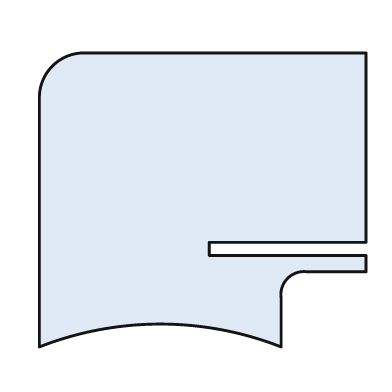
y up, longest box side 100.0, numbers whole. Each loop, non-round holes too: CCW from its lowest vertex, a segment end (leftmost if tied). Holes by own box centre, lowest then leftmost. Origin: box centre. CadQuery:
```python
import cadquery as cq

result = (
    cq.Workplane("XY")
    .moveTo(-50.0, -45.0)
    .threePointArc((-13.0, -38.0), (24.0, -45.0))
    .lineTo(24.0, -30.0)
    .threePointArc((26.0, -24.0), (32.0, -22.0))
    .lineTo(50.0, -22.0)
    .lineTo(50.0, -17.0)
    .lineTo(2.0, -17.0)
    .lineTo(2.0, -13.0)
    .lineTo(50.0, -13.0)
    .lineTo(50.0, 45.0)
    .lineTo(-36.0, 45.0)
    .threePointArc((-46.0, 41.0), (-50.0, 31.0))
    .close()
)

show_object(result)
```